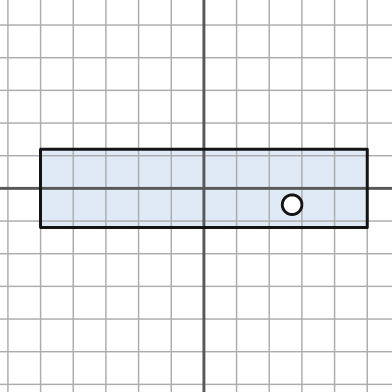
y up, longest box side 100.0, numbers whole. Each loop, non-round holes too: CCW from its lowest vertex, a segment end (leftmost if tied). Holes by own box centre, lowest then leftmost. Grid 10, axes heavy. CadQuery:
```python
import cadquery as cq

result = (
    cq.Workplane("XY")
    .moveTo(-50.0, -12.0)
    .lineTo(50.0, -12.0)
    .lineTo(50.0, 12.0)
    .lineTo(-50.0, 12.0)
    .close()
    .moveTo(27.0, -5.0)
    .circle(3.0)
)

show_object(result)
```